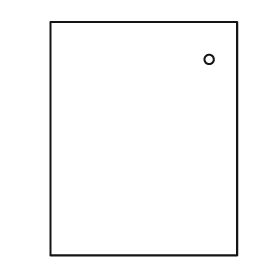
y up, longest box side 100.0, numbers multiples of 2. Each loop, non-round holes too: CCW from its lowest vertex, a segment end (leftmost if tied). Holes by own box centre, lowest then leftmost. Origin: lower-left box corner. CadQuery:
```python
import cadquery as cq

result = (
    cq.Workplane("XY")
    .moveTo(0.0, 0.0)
    .lineTo(80.0, 0.0)
    .lineTo(80.0, 100.0)
    .lineTo(0.0, 100.0)
    .close()
    .moveTo(68.0, 84.0)
    .circle(2.0)
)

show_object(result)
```